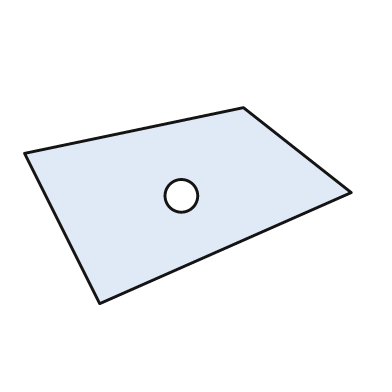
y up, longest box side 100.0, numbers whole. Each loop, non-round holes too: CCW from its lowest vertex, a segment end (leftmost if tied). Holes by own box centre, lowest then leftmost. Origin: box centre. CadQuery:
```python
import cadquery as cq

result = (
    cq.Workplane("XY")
    .moveTo(-27.0, -30.0)
    .lineTo(50.0, 4.0)
    .lineTo(17.0, 30.0)
    .lineTo(-50.0, 16.0)
    .close()
    .moveTo(-2.0, 3.0)
    .circle(5.0)
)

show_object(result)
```